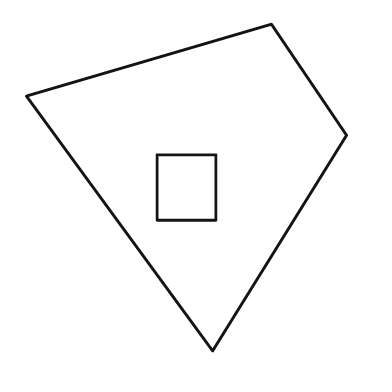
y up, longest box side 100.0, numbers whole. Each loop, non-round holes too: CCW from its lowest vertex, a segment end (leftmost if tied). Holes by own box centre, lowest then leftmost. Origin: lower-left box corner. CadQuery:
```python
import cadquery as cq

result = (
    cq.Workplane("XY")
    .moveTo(57.0, 0.0)
    .lineTo(98.0, 66.0)
    .lineTo(75.0, 100.0)
    .lineTo(0.0, 78.0)
    .close()
    .moveTo(40.0, 40.0)
    .lineTo(58.0, 40.0)
    .lineTo(58.0, 60.0)
    .lineTo(40.0, 60.0)
    .close()
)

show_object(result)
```